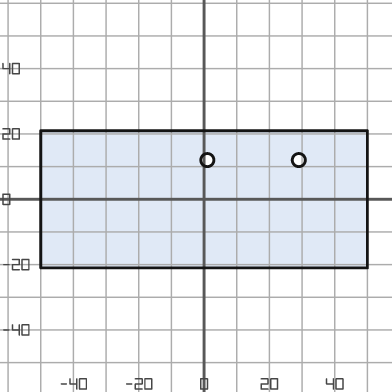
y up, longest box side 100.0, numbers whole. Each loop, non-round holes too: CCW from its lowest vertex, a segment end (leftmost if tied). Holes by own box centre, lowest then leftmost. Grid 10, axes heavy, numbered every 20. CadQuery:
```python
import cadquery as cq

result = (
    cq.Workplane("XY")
    .moveTo(-50.0, -21.0)
    .lineTo(50.0, -21.0)
    .lineTo(50.0, 21.0)
    .lineTo(-50.0, 21.0)
    .close()
    .moveTo(1.0, 12.0)
    .circle(2.0)
    .moveTo(29.0, 12.0)
    .circle(2.0)
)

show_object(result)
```